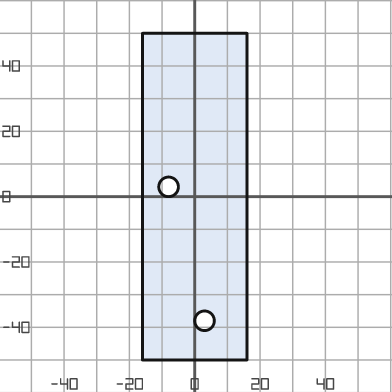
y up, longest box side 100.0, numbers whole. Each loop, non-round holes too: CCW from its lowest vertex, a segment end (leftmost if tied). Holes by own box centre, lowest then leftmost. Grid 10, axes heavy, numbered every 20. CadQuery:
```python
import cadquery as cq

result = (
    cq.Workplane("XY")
    .moveTo(-16.0, -50.0)
    .lineTo(16.0, -50.0)
    .lineTo(16.0, 50.0)
    .lineTo(-16.0, 50.0)
    .close()
    .moveTo(3.0, -38.0)
    .circle(3.0)
    .moveTo(-8.0, 3.0)
    .circle(3.0)
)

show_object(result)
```